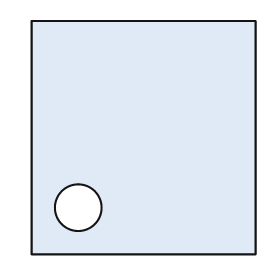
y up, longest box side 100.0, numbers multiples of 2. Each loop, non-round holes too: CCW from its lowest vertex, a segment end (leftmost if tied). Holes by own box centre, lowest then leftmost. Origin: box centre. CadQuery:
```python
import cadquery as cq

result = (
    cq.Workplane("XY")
    .moveTo(-48.0, -50.0)
    .lineTo(48.0, -50.0)
    .lineTo(48.0, 50.0)
    .lineTo(-48.0, 50.0)
    .close()
    .moveTo(-28.0, -30.0)
    .circle(10.0)
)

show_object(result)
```